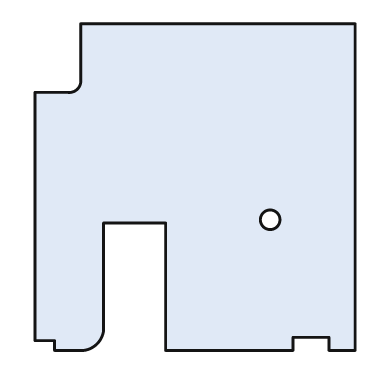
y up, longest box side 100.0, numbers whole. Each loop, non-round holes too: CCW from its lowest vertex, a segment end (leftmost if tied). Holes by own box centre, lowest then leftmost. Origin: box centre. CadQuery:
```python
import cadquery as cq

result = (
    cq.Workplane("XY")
    .moveTo(-43.0, -50.0)
    .lineTo(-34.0, -50.0)
    .threePointArc((-30.0, -48.0), (-28.0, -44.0))
    .lineTo(-28.0, -11.0)
    .lineTo(-9.0, -11.0)
    .lineTo(-9.0, -50.0)
    .lineTo(30.0, -50.0)
    .lineTo(30.0, -46.0)
    .lineTo(41.0, -46.0)
    .lineTo(41.0, -50.0)
    .lineTo(49.0, -50.0)
    .lineTo(49.0, 50.0)
    .lineTo(-35.0, 50.0)
    .lineTo(-35.0, 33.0)
    .threePointArc((-36.0, 30.0), (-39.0, 29.0))
    .lineTo(-49.0, 29.0)
    .lineTo(-49.0, -47.0)
    .lineTo(-43.0, -47.0)
    .close()
    .moveTo(23.0, -10.0)
    .circle(3.0)
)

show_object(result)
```